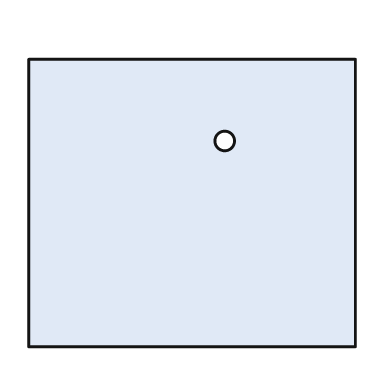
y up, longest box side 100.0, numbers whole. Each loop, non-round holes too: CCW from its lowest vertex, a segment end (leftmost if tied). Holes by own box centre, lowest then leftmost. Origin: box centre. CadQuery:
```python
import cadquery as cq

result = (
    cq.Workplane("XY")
    .moveTo(-50.0, -44.0)
    .lineTo(50.0, -44.0)
    .lineTo(50.0, 44.0)
    .lineTo(-50.0, 44.0)
    .close()
    .moveTo(10.0, 19.0)
    .circle(3.0)
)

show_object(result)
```